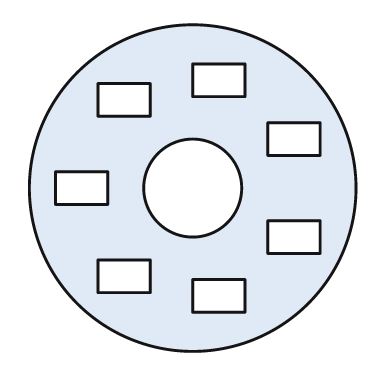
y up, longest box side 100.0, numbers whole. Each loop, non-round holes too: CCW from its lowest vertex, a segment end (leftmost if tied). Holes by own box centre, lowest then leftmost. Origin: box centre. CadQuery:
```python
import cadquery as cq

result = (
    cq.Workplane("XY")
    .moveTo(0.0, 0.0)
    .circle(50.0)
    .moveTo(0.0, -38.0)
    .lineTo(16.0, -38.0)
    .lineTo(16.0, -28.0)
    .lineTo(0.0, -28.0)
    .close()
    .moveTo(-29.0, -32.0)
    .lineTo(-13.0, -32.0)
    .lineTo(-13.0, -22.0)
    .lineTo(-29.0, -22.0)
    .close()
    .moveTo(23.0, -20.0)
    .lineTo(39.0, -20.0)
    .lineTo(39.0, -10.0)
    .lineTo(23.0, -10.0)
    .close()
    .moveTo(-42.0, -5.0)
    .lineTo(-26.0, -5.0)
    .lineTo(-26.0, 5.0)
    .lineTo(-42.0, 5.0)
    .close()
    .moveTo(0.0, 0.0)
    .circle(15.0)
    .moveTo(23.0, 10.0)
    .lineTo(39.0, 10.0)
    .lineTo(39.0, 20.0)
    .lineTo(23.0, 20.0)
    .close()
    .moveTo(-29.0, 22.0)
    .lineTo(-13.0, 22.0)
    .lineTo(-13.0, 32.0)
    .lineTo(-29.0, 32.0)
    .close()
    .moveTo(0.0, 28.0)
    .lineTo(16.0, 28.0)
    .lineTo(16.0, 38.0)
    .lineTo(0.0, 38.0)
    .close()
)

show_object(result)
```